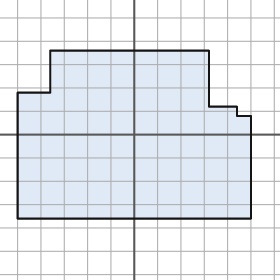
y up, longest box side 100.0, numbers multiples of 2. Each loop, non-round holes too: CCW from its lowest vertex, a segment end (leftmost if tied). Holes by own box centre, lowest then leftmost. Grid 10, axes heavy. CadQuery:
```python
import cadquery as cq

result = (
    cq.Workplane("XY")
    .moveTo(-50.0, -36.0)
    .lineTo(50.0, -36.0)
    .lineTo(50.0, 8.0)
    .lineTo(44.0, 8.0)
    .lineTo(44.0, 12.0)
    .lineTo(32.0, 12.0)
    .lineTo(32.0, 36.0)
    .lineTo(-36.0, 36.0)
    .lineTo(-36.0, 18.0)
    .lineTo(-50.0, 18.0)
    .close()
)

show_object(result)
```